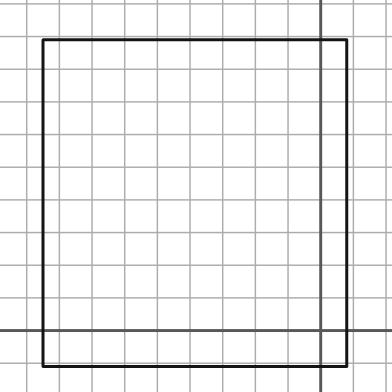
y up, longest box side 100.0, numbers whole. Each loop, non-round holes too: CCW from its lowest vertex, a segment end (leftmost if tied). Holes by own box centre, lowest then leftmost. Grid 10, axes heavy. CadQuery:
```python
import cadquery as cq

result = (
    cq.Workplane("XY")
    .moveTo(-85.0, -11.0)
    .lineTo(8.0, -11.0)
    .lineTo(8.0, 89.0)
    .lineTo(-85.0, 89.0)
    .close()
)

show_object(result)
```